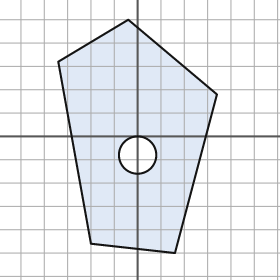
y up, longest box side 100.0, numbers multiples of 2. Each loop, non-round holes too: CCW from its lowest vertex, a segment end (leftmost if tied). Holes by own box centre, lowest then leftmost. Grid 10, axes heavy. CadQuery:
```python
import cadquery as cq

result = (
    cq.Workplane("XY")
    .moveTo(16.0, -50.0)
    .lineTo(34.0, 18.0)
    .lineTo(-4.0, 50.0)
    .lineTo(-34.0, 32.0)
    .lineTo(-20.0, -46.0)
    .close()
    .moveTo(0.0, -8.0)
    .circle(8.0)
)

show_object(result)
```